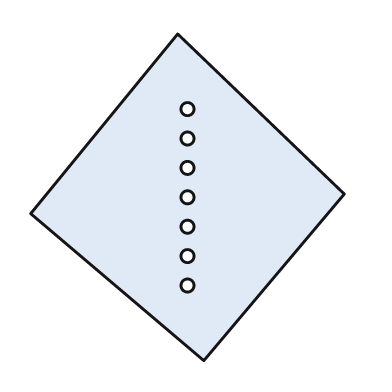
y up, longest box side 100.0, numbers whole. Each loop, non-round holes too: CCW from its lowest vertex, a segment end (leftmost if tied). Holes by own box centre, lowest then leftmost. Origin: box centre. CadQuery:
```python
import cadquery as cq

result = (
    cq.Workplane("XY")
    .moveTo(5.0, -50.0)
    .lineTo(48.0, 1.0)
    .lineTo(-3.0, 50.0)
    .lineTo(-48.0, -5.0)
    .close()
    .moveTo(0.0, -27.0)
    .circle(2.0)
    .moveTo(0.0, -18.0)
    .circle(2.0)
    .moveTo(0.0, -9.0)
    .circle(2.0)
    .moveTo(0.0, 0.0)
    .circle(2.0)
    .moveTo(0.0, 9.0)
    .circle(2.0)
    .moveTo(0.0, 18.0)
    .circle(2.0)
    .moveTo(0.0, 27.0)
    .circle(2.0)
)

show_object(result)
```